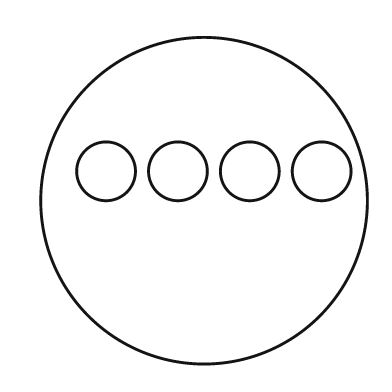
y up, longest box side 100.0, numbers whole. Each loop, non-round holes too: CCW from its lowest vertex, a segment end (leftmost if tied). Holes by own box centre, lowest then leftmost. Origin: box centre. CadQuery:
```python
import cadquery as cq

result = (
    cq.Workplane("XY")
    .moveTo(0.0, 0.0)
    .circle(50.0)
    .moveTo(-30.0, 9.0)
    .circle(9.0)
    .moveTo(-8.0, 9.0)
    .circle(9.0)
    .moveTo(14.0, 9.0)
    .circle(9.0)
    .moveTo(36.0, 9.0)
    .circle(9.0)
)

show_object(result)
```